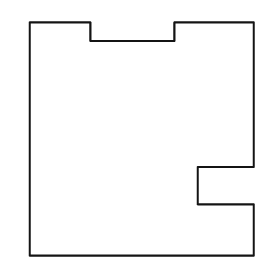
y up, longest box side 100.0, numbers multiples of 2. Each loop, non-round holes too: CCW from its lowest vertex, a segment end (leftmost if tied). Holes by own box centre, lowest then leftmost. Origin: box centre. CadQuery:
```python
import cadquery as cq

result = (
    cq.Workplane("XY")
    .moveTo(-48.0, -50.0)
    .lineTo(48.0, -50.0)
    .lineTo(48.0, -28.0)
    .lineTo(24.0, -28.0)
    .lineTo(24.0, -12.0)
    .lineTo(48.0, -12.0)
    .lineTo(48.0, 50.0)
    .lineTo(14.0, 50.0)
    .lineTo(14.0, 42.0)
    .lineTo(-22.0, 42.0)
    .lineTo(-22.0, 50.0)
    .lineTo(-48.0, 50.0)
    .close()
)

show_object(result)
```